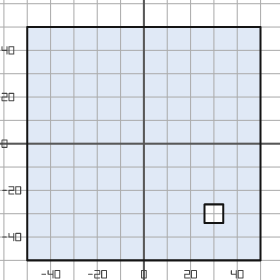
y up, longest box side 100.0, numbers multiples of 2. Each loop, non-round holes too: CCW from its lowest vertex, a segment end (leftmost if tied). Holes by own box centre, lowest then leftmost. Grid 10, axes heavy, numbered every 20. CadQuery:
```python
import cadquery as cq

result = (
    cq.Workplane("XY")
    .moveTo(-50.0, -50.0)
    .lineTo(50.0, -50.0)
    .lineTo(50.0, 50.0)
    .lineTo(-50.0, 50.0)
    .close()
    .moveTo(26.0, -34.0)
    .lineTo(34.0, -34.0)
    .lineTo(34.0, -26.0)
    .lineTo(26.0, -26.0)
    .close()
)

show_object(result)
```